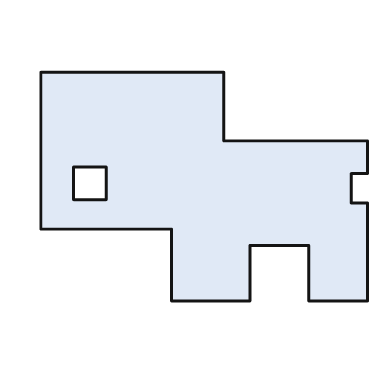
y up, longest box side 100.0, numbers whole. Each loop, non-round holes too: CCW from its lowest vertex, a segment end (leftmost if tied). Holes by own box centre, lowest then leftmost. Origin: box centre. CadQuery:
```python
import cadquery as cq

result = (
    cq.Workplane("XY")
    .moveTo(-10.0, -35.0)
    .lineTo(14.0, -35.0)
    .lineTo(14.0, -18.0)
    .lineTo(32.0, -18.0)
    .lineTo(32.0, -35.0)
    .lineTo(50.0, -35.0)
    .lineTo(50.0, -5.0)
    .lineTo(45.0, -5.0)
    .lineTo(45.0, 4.0)
    .lineTo(50.0, 4.0)
    .lineTo(50.0, 14.0)
    .lineTo(6.0, 14.0)
    .lineTo(6.0, 35.0)
    .lineTo(-50.0, 35.0)
    .lineTo(-50.0, -13.0)
    .lineTo(-10.0, -13.0)
    .close()
    .moveTo(-40.0, -4.0)
    .lineTo(-30.0, -4.0)
    .lineTo(-30.0, 6.0)
    .lineTo(-40.0, 6.0)
    .close()
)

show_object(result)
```